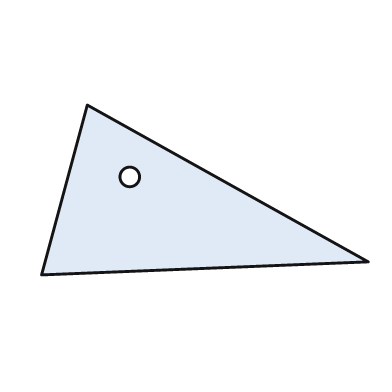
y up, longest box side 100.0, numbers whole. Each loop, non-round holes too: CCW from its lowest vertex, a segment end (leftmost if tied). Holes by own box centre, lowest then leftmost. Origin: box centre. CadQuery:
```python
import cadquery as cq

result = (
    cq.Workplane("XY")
    .moveTo(-50.0, -26.0)
    .lineTo(50.0, -22.0)
    .lineTo(-36.0, 26.0)
    .close()
    .moveTo(-23.0, 4.0)
    .circle(3.0)
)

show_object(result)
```